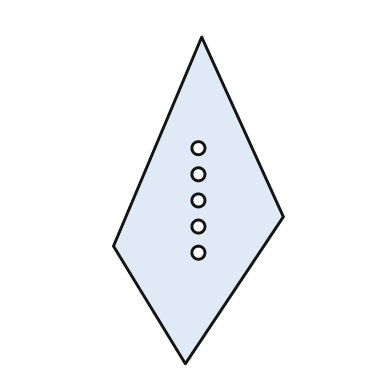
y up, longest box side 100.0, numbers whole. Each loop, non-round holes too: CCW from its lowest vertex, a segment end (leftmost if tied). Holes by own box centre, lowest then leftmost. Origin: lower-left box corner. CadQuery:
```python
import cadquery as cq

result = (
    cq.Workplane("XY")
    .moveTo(22.0, 0.0)
    .lineTo(52.0, 45.0)
    .lineTo(27.0, 100.0)
    .lineTo(0.0, 36.0)
    .close()
    .moveTo(26.0, 34.0)
    .circle(2.0)
    .moveTo(26.0, 42.0)
    .circle(2.0)
    .moveTo(26.0, 50.0)
    .circle(2.0)
    .moveTo(26.0, 58.0)
    .circle(2.0)
    .moveTo(26.0, 66.0)
    .circle(2.0)
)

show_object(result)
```